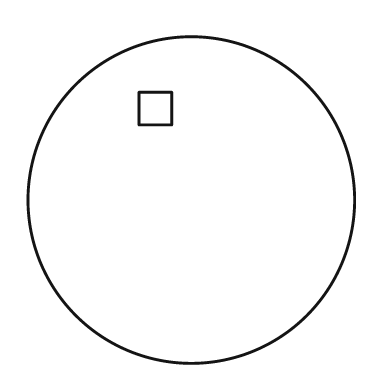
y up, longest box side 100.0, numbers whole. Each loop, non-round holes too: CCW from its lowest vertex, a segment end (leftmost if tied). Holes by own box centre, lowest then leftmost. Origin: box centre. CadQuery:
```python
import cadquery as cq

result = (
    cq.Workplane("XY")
    .moveTo(0.0, 0.0)
    .circle(50.0)
    .moveTo(-16.0, 23.0)
    .lineTo(-6.0, 23.0)
    .lineTo(-6.0, 33.0)
    .lineTo(-16.0, 33.0)
    .close()
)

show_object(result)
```